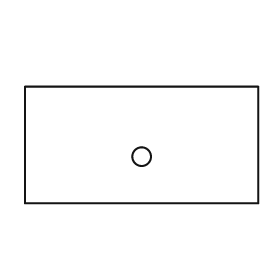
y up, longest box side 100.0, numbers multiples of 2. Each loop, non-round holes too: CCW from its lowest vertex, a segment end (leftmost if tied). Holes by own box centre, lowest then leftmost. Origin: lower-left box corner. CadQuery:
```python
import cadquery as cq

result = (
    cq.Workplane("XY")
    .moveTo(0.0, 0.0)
    .lineTo(100.0, 0.0)
    .lineTo(100.0, 50.0)
    .lineTo(0.0, 50.0)
    .close()
    .moveTo(50.0, 20.0)
    .circle(4.0)
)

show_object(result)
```